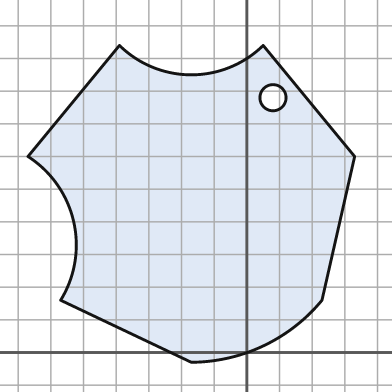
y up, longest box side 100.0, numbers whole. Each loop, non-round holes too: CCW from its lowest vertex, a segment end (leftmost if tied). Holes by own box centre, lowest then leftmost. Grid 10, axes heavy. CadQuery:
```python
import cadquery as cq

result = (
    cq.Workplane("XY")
    .moveTo(-17.0, -3.0)
    .threePointArc((5.0, 2.0), (23.0, 16.0))
    .lineTo(33.0, 60.0)
    .lineTo(5.0, 94.0)
    .threePointArc((-17.0, 85.0), (-39.0, 94.0))
    .lineTo(-67.0, 60.0)
    .threePointArc((-53.0, 40.0), (-57.0, 16.0))
    .close()
    .moveTo(8.0, 78.0)
    .circle(4.0)
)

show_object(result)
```